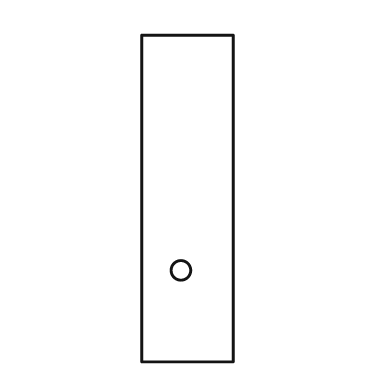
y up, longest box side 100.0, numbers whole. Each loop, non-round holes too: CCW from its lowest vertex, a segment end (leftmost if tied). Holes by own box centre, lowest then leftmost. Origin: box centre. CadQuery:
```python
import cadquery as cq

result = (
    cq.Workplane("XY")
    .moveTo(-14.0, -50.0)
    .lineTo(14.0, -50.0)
    .lineTo(14.0, 50.0)
    .lineTo(-14.0, 50.0)
    .close()
    .moveTo(-2.0, -22.0)
    .circle(3.0)
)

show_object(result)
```